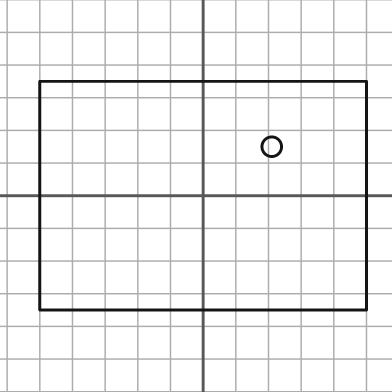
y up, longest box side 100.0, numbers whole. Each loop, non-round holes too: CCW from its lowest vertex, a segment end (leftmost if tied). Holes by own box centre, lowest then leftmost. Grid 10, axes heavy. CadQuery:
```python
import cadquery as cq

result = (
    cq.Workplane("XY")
    .moveTo(-50.0, -35.0)
    .lineTo(50.0, -35.0)
    .lineTo(50.0, 35.0)
    .lineTo(-50.0, 35.0)
    .close()
    .moveTo(21.0, 15.0)
    .circle(3.0)
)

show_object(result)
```